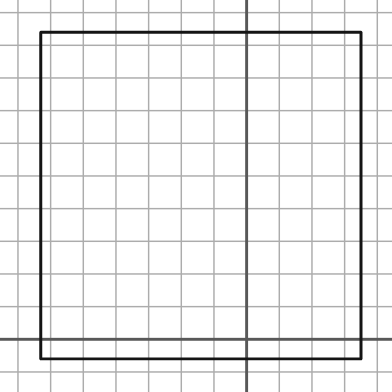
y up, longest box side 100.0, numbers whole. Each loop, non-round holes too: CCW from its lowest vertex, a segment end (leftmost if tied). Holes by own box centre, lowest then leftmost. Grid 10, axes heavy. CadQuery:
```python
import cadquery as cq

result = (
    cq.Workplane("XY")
    .moveTo(-63.0, -6.0)
    .lineTo(35.0, -6.0)
    .lineTo(35.0, 94.0)
    .lineTo(-63.0, 94.0)
    .close()
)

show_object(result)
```